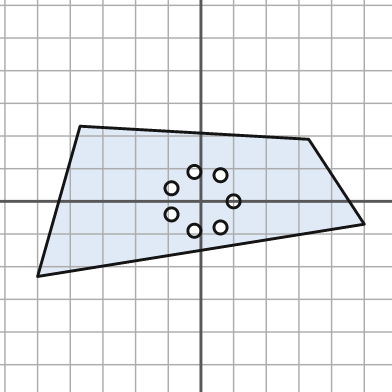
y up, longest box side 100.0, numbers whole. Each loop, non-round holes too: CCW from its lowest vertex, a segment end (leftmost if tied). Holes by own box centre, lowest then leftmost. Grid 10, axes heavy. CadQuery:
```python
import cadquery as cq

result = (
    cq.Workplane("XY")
    .moveTo(-50.0, -23.0)
    .lineTo(50.0, -7.0)
    .lineTo(33.0, 19.0)
    .lineTo(-37.0, 23.0)
    .close()
    .moveTo(-2.0, -9.0)
    .circle(2.0)
    .moveTo(6.0, -8.0)
    .circle(2.0)
    .moveTo(-9.0, -4.0)
    .circle(2.0)
    .moveTo(10.0, 0.0)
    .circle(2.0)
    .moveTo(-9.0, 4.0)
    .circle(2.0)
    .moveTo(6.0, 8.0)
    .circle(2.0)
    .moveTo(-2.0, 9.0)
    .circle(2.0)
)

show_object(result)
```